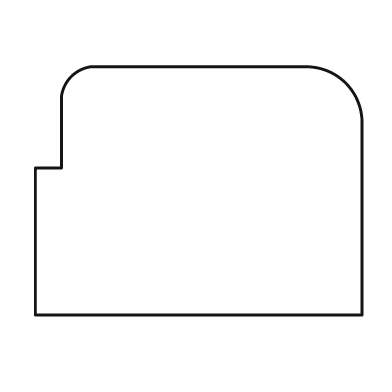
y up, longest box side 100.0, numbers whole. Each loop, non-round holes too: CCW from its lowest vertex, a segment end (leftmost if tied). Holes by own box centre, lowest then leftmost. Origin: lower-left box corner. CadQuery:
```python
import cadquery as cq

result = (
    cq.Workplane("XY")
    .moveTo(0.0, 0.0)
    .lineTo(100.0, 0.0)
    .lineTo(100.0, 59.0)
    .threePointArc((95.0, 71.0), (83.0, 76.0))
    .lineTo(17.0, 76.0)
    .threePointArc((11.0, 73.0), (8.0, 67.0))
    .lineTo(8.0, 45.0)
    .lineTo(0.0, 45.0)
    .close()
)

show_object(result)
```